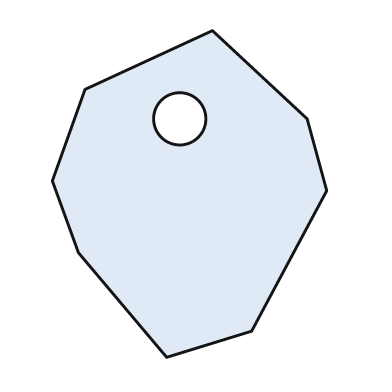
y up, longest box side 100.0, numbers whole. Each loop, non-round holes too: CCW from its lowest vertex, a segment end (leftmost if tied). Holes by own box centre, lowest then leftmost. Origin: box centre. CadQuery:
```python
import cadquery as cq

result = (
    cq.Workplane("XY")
    .moveTo(-7.0, -50.0)
    .lineTo(19.0, -42.0)
    .lineTo(42.0, 1.0)
    .lineTo(36.0, 23.0)
    .lineTo(7.0, 50.0)
    .lineTo(-32.0, 32.0)
    .lineTo(-42.0, 4.0)
    .lineTo(-34.0, -18.0)
    .close()
    .moveTo(-3.0, 23.0)
    .circle(8.0)
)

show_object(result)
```